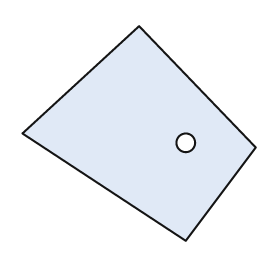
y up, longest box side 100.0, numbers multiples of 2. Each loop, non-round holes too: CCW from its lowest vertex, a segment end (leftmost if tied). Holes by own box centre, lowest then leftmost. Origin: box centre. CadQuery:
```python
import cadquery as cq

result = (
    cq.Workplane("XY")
    .moveTo(20.0, -46.0)
    .lineTo(50.0, -6.0)
    .lineTo(0.0, 46.0)
    .lineTo(-50.0, 0.0)
    .close()
    .moveTo(20.0, -4.0)
    .circle(4.0)
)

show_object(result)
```